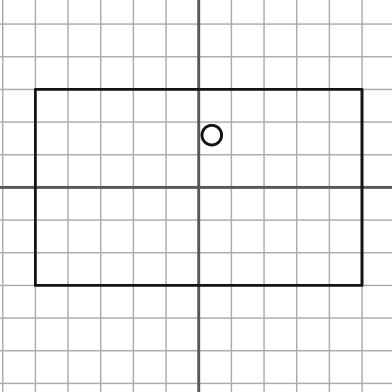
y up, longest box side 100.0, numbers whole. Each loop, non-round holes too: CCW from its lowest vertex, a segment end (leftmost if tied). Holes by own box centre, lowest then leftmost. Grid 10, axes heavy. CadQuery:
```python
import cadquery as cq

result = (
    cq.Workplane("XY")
    .moveTo(-50.0, -30.0)
    .lineTo(50.0, -30.0)
    .lineTo(50.0, 30.0)
    .lineTo(-50.0, 30.0)
    .close()
    .moveTo(4.0, 16.0)
    .circle(3.0)
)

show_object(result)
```